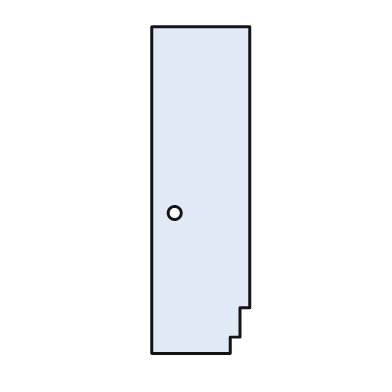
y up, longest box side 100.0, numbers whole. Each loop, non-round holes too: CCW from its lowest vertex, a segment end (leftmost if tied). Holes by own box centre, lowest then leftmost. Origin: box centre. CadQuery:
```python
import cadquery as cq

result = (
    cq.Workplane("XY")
    .moveTo(-15.0, -50.0)
    .lineTo(9.0, -50.0)
    .lineTo(9.0, -45.0)
    .lineTo(12.0, -45.0)
    .lineTo(12.0, -36.0)
    .lineTo(15.0, -36.0)
    .lineTo(15.0, 50.0)
    .lineTo(-15.0, 50.0)
    .close()
    .moveTo(-8.0, -7.0)
    .circle(2.0)
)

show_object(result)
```